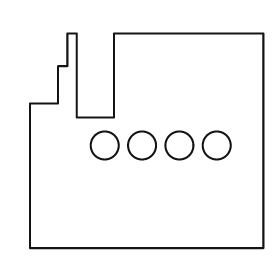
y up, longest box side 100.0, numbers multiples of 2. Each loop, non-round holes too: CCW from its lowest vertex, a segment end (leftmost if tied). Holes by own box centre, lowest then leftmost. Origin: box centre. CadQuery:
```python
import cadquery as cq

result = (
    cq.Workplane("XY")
    .moveTo(-50.0, -46.0)
    .lineTo(50.0, -46.0)
    .lineTo(50.0, 46.0)
    .lineTo(-14.0, 46.0)
    .lineTo(-14.0, 10.0)
    .lineTo(-30.0, 10.0)
    .lineTo(-30.0, 46.0)
    .lineTo(-34.0, 46.0)
    .lineTo(-34.0, 32.0)
    .lineTo(-38.0, 32.0)
    .lineTo(-38.0, 16.0)
    .lineTo(-50.0, 16.0)
    .close()
    .moveTo(-18.0, -2.0)
    .circle(6.0)
    .moveTo(-2.0, -2.0)
    .circle(6.0)
    .moveTo(14.0, -2.0)
    .circle(6.0)
    .moveTo(30.0, -2.0)
    .circle(6.0)
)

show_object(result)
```